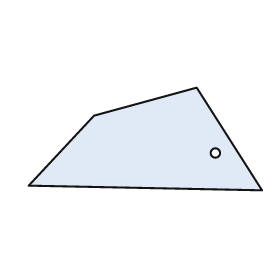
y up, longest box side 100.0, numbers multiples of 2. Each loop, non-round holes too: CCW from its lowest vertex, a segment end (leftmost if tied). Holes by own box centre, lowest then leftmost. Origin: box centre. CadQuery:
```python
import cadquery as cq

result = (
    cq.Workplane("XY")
    .moveTo(50.0, -22.0)
    .lineTo(22.0, 22.0)
    .lineTo(-22.0, 10.0)
    .lineTo(-50.0, -20.0)
    .close()
    .moveTo(30.0, -6.0)
    .circle(2.0)
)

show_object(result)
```